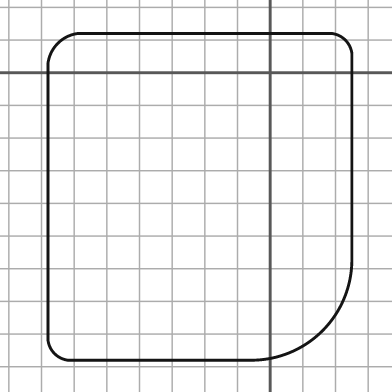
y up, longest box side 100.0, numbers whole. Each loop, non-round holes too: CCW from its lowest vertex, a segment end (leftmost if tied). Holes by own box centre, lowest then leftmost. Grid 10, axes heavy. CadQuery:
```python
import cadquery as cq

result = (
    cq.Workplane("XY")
    .moveTo(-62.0, -88.0)
    .lineTo(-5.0, -88.0)
    .threePointArc((16.0, -79.0), (25.0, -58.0))
    .lineTo(25.0, 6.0)
    .threePointArc((23.0, 10.0), (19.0, 12.0))
    .lineTo(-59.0, 12.0)
    .threePointArc((-65.0, 9.0), (-68.0, 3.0))
    .lineTo(-68.0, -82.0)
    .threePointArc((-66.0, -86.0), (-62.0, -88.0))
    .close()
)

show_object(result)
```